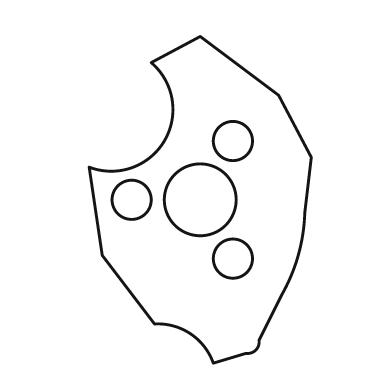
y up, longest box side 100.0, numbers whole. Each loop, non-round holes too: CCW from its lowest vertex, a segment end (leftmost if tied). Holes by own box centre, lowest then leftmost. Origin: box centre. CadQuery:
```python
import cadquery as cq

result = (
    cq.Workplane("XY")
    .moveTo(4.0, -50.0)
    .lineTo(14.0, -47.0)
    .threePointArc((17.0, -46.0), (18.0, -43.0))
    .lineTo(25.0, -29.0)
    .threePointArc((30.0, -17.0), (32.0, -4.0))
    .lineTo(34.0, 13.0)
    .lineTo(24.0, 32.0)
    .lineTo(0.0, 50.0)
    .lineTo(-15.0, 42.0)
    .threePointArc((-11.0, 18.0), (-34.0, 10.0))
    .lineTo(-30.0, -17.0)
    .lineTo(-14.0, -38.0)
    .threePointArc((-3.0, -41.0), (4.0, -50.0))
    .close()
    .moveTo(10.0, -18.0)
    .circle(6.0)
    .moveTo(-21.0, 0.0)
    .circle(6.0)
    .moveTo(0.0, 0.0)
    .circle(11.0)
    .moveTo(10.0, 18.0)
    .circle(6.0)
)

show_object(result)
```